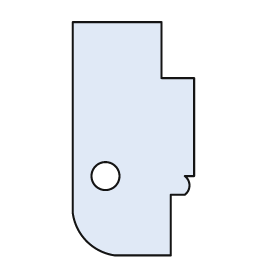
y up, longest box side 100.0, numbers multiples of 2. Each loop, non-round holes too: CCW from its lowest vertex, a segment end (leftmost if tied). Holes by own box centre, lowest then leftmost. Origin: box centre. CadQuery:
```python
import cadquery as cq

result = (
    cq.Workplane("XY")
    .moveTo(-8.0, -50.0)
    .lineTo(16.0, -50.0)
    .lineTo(16.0, -24.0)
    .lineTo(22.0, -24.0)
    .threePointArc((24.0, -20.0), (22.0, -16.0))
    .lineTo(26.0, -16.0)
    .lineTo(26.0, 26.0)
    .lineTo(12.0, 26.0)
    .lineTo(12.0, 50.0)
    .lineTo(-26.0, 50.0)
    .lineTo(-26.0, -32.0)
    .threePointArc((-20.0, -44.0), (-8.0, -50.0))
    .close()
    .moveTo(-12.0, -16.0)
    .circle(6.0)
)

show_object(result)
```